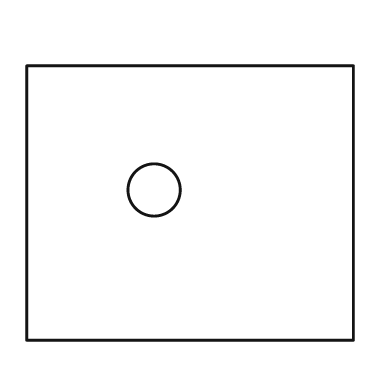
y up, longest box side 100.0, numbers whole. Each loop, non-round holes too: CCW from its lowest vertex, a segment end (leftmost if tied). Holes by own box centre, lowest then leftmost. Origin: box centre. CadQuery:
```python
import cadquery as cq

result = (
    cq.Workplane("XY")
    .moveTo(-50.0, -42.0)
    .lineTo(50.0, -42.0)
    .lineTo(50.0, 42.0)
    .lineTo(-50.0, 42.0)
    .close()
    .moveTo(-11.0, 4.0)
    .circle(8.0)
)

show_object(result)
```